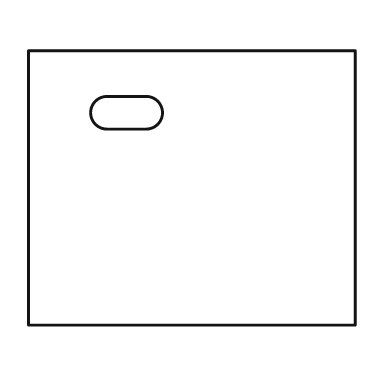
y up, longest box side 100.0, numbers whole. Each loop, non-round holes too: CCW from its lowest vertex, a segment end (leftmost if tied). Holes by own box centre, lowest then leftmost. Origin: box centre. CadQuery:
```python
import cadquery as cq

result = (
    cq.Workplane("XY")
    .moveTo(-50.0, -42.0)
    .lineTo(50.0, -42.0)
    .lineTo(50.0, 42.0)
    .lineTo(-50.0, 42.0)
    .close()
    .moveTo(-26.0, 18.0)
    .lineTo(-14.0, 18.0)
    .threePointArc((-9.0, 23.0), (-14.0, 28.0))
    .lineTo(-26.0, 28.0)
    .threePointArc((-31.0, 23.0), (-26.0, 18.0))
    .close()
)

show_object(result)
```